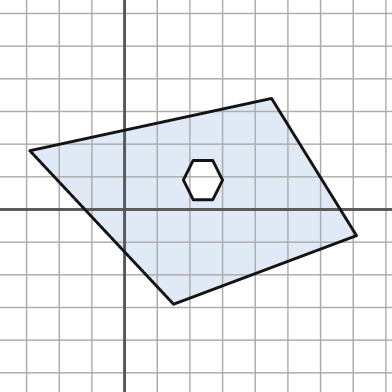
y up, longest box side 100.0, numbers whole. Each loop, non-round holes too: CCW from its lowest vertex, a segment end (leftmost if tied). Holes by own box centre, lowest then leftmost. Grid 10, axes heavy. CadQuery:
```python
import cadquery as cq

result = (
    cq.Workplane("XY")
    .moveTo(15.0, -29.0)
    .lineTo(71.0, -8.0)
    .lineTo(45.0, 34.0)
    .lineTo(-29.0, 18.0)
    .close()
    .moveTo(21.0, 3.0)
    .lineTo(27.0, 3.0)
    .lineTo(30.0, 9.0)
    .lineTo(27.0, 15.0)
    .lineTo(21.0, 15.0)
    .lineTo(18.0, 9.0)
    .close()
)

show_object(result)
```